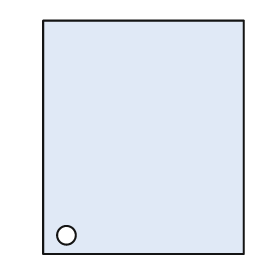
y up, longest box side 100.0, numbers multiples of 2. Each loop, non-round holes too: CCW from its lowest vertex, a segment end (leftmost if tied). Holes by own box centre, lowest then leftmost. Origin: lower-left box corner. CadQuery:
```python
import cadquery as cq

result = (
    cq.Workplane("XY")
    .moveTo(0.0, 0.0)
    .lineTo(86.0, 0.0)
    .lineTo(86.0, 100.0)
    .lineTo(0.0, 100.0)
    .close()
    .moveTo(10.0, 8.0)
    .circle(4.0)
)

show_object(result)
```